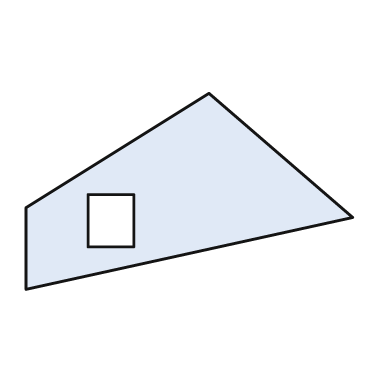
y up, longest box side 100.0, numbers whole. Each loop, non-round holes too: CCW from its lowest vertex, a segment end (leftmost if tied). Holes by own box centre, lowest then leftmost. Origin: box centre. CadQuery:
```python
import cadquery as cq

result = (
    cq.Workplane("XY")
    .moveTo(-50.0, -30.0)
    .lineTo(50.0, -8.0)
    .lineTo(6.0, 30.0)
    .lineTo(-50.0, -5.0)
    .close()
    .moveTo(-31.0, -17.0)
    .lineTo(-17.0, -17.0)
    .lineTo(-17.0, -1.0)
    .lineTo(-31.0, -1.0)
    .close()
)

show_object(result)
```